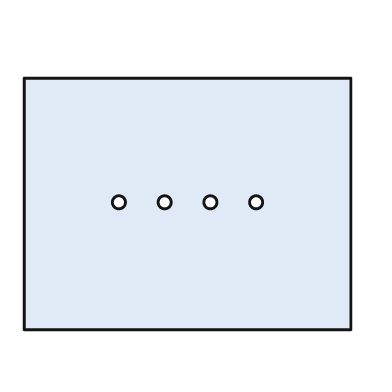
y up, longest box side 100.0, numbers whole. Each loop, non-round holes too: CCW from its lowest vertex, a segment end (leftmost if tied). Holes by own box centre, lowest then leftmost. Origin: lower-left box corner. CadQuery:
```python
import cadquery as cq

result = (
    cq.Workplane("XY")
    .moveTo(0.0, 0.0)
    .lineTo(100.0, 0.0)
    .lineTo(100.0, 77.0)
    .lineTo(0.0, 77.0)
    .close()
    .moveTo(29.0, 39.0)
    .circle(2.0)
    .moveTo(43.0, 39.0)
    .circle(2.0)
    .moveTo(57.0, 39.0)
    .circle(2.0)
    .moveTo(71.0, 39.0)
    .circle(2.0)
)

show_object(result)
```